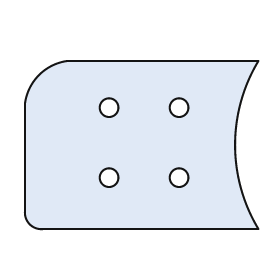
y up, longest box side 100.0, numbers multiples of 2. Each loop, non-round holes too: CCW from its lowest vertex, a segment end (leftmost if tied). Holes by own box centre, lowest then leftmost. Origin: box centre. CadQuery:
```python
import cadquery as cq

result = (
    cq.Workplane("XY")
    .moveTo(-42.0, -36.0)
    .lineTo(50.0, -36.0)
    .threePointArc((40.0, 0.0), (50.0, 36.0))
    .lineTo(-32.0, 36.0)
    .threePointArc((-44.0, 30.0), (-50.0, 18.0))
    .lineTo(-50.0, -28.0)
    .threePointArc((-48.0, -34.0), (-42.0, -36.0))
    .close()
    .moveTo(-14.0, -14.0)
    .circle(4.0)
    .moveTo(16.0, -14.0)
    .circle(4.0)
    .moveTo(-14.0, 16.0)
    .circle(4.0)
    .moveTo(16.0, 16.0)
    .circle(4.0)
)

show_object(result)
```